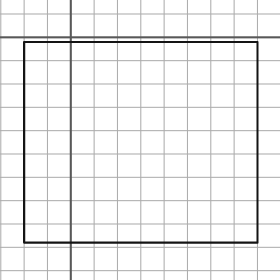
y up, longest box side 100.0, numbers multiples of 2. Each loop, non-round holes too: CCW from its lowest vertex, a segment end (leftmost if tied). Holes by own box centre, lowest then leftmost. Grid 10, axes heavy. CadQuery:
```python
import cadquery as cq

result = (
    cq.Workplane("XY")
    .moveTo(-20.0, -88.0)
    .lineTo(80.0, -88.0)
    .lineTo(80.0, -2.0)
    .lineTo(-20.0, -2.0)
    .close()
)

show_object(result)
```